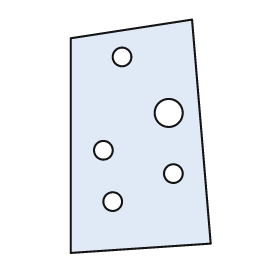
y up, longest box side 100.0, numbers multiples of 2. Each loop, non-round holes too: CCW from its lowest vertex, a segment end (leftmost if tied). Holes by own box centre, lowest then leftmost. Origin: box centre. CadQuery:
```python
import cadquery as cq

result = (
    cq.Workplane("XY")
    .moveTo(-30.0, -50.0)
    .lineTo(30.0, -46.0)
    .lineTo(22.0, 50.0)
    .lineTo(-30.0, 42.0)
    .close()
    .moveTo(-12.0, -28.0)
    .circle(4.0)
    .moveTo(14.0, -16.0)
    .circle(4.0)
    .moveTo(-16.0, -6.0)
    .circle(4.0)
    .moveTo(12.0, 10.0)
    .circle(6.0)
    .moveTo(-8.0, 34.0)
    .circle(4.0)
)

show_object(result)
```